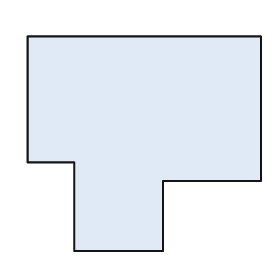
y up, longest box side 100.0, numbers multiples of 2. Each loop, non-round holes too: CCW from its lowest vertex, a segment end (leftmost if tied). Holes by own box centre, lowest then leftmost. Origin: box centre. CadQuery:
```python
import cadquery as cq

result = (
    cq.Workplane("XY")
    .moveTo(-30.0, -46.0)
    .lineTo(8.0, -46.0)
    .lineTo(8.0, -16.0)
    .lineTo(50.0, -16.0)
    .lineTo(50.0, 46.0)
    .lineTo(-50.0, 46.0)
    .lineTo(-50.0, -8.0)
    .lineTo(-30.0, -8.0)
    .close()
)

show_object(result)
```